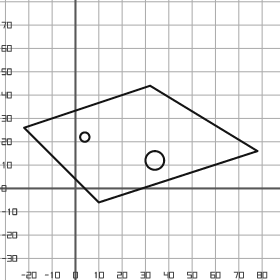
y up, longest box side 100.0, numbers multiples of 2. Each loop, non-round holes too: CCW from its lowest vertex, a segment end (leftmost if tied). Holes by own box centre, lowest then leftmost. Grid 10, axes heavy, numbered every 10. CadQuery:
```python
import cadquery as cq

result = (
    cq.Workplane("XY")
    .moveTo(10.0, -6.0)
    .lineTo(78.0, 16.0)
    .lineTo(32.0, 44.0)
    .lineTo(-22.0, 26.0)
    .close()
    .moveTo(34.0, 12.0)
    .circle(4.0)
    .moveTo(4.0, 22.0)
    .circle(2.0)
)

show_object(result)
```